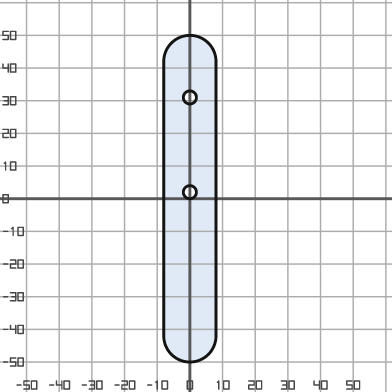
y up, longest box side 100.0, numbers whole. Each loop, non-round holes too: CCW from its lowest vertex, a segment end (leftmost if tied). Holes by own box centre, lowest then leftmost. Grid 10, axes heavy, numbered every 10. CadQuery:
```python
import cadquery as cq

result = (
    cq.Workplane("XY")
    .moveTo(-8.0, -42.0)
    .threePointArc((0.0, -50.0), (8.0, -42.0))
    .lineTo(8.0, 42.0)
    .threePointArc((0.0, 50.0), (-8.0, 42.0))
    .close()
    .moveTo(0.0, 2.0)
    .circle(2.0)
    .moveTo(0.0, 31.0)
    .circle(2.0)
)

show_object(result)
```